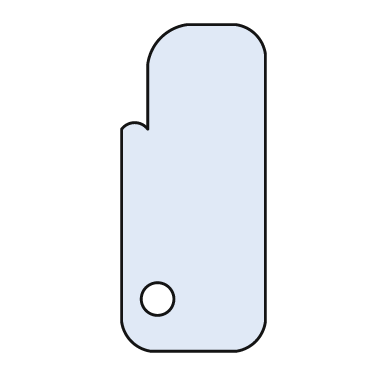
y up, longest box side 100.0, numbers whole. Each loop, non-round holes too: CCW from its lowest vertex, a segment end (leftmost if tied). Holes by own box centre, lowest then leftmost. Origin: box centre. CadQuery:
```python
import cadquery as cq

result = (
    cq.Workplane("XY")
    .moveTo(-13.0, -50.0)
    .lineTo(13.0, -50.0)
    .threePointArc((19.0, -47.0), (22.0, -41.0))
    .lineTo(22.0, 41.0)
    .threePointArc((19.0, 47.0), (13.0, 50.0))
    .lineTo(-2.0, 50.0)
    .threePointArc((-10.0, 46.0), (-14.0, 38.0))
    .lineTo(-14.0, 18.0)
    .threePointArc((-18.0, 20.0), (-22.0, 18.0))
    .lineTo(-22.0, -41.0)
    .threePointArc((-19.0, -47.0), (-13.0, -50.0))
    .close()
    .moveTo(-11.0, -34.0)
    .circle(5.0)
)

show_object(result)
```